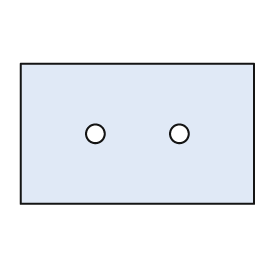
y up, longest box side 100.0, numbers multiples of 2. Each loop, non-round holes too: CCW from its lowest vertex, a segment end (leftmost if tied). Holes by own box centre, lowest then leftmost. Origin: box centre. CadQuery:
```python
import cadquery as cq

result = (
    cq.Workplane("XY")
    .moveTo(-50.0, -30.0)
    .lineTo(50.0, -30.0)
    .lineTo(50.0, 30.0)
    .lineTo(-50.0, 30.0)
    .close()
    .moveTo(-18.0, 0.0)
    .circle(4.0)
    .moveTo(18.0, 0.0)
    .circle(4.0)
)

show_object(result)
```